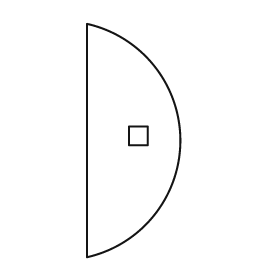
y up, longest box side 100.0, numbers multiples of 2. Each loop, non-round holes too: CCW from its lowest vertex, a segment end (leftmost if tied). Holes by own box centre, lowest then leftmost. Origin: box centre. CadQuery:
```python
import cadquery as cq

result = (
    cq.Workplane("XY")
    .moveTo(-20.0, -50.0)
    .threePointArc((20.0, 0.0), (-20.0, 50.0))
    .close()
    .moveTo(-2.0, -2.0)
    .lineTo(6.0, -2.0)
    .lineTo(6.0, 6.0)
    .lineTo(-2.0, 6.0)
    .close()
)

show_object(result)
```